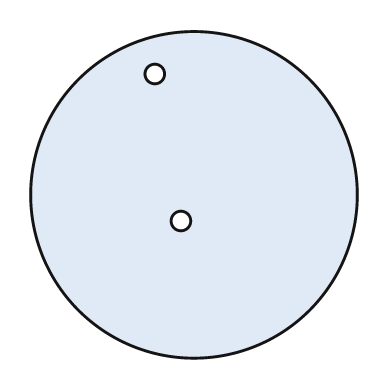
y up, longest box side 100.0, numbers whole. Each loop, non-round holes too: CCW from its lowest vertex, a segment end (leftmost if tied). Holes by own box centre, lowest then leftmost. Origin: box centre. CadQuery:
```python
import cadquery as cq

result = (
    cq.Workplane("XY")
    .moveTo(0.0, 0.0)
    .circle(50.0)
    .moveTo(-4.0, -8.0)
    .circle(3.0)
    .moveTo(-12.0, 37.0)
    .circle(3.0)
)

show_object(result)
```